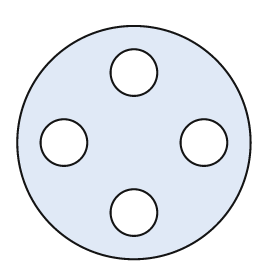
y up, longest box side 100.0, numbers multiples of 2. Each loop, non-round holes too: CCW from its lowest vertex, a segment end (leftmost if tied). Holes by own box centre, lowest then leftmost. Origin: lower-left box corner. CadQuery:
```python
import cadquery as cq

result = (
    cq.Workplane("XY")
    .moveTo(50.0, 50.0)
    .circle(50.0)
    .moveTo(50.0, 20.0)
    .circle(10.0)
    .moveTo(20.0, 50.0)
    .circle(10.0)
    .moveTo(80.0, 50.0)
    .circle(10.0)
    .moveTo(50.0, 80.0)
    .circle(10.0)
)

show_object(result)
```